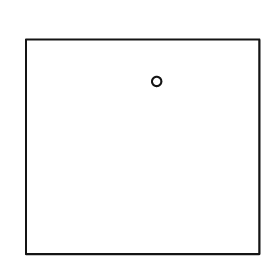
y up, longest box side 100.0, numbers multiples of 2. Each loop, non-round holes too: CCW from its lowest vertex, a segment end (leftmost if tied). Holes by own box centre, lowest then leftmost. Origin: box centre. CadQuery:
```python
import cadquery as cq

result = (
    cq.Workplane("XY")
    .moveTo(-50.0, -46.0)
    .lineTo(50.0, -46.0)
    .lineTo(50.0, 46.0)
    .lineTo(-50.0, 46.0)
    .close()
    .moveTo(6.0, 28.0)
    .circle(2.0)
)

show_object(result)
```